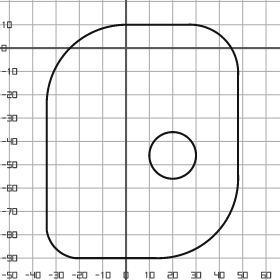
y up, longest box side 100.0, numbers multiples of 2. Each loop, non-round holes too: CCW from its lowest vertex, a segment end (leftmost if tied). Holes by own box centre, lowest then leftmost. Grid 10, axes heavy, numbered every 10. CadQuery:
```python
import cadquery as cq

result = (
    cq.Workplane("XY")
    .moveTo(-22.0, -90.0)
    .lineTo(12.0, -90.0)
    .threePointArc((38.0, -80.0), (48.0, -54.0))
    .lineTo(48.0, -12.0)
    .threePointArc((42.0, 4.0), (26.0, 10.0))
    .lineTo(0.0, 10.0)
    .threePointArc((-24.0, 0.0), (-34.0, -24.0))
    .lineTo(-34.0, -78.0)
    .threePointArc((-30.0, -86.0), (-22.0, -90.0))
    .close()
    .moveTo(20.0, -46.0)
    .circle(10.0)
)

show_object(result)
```